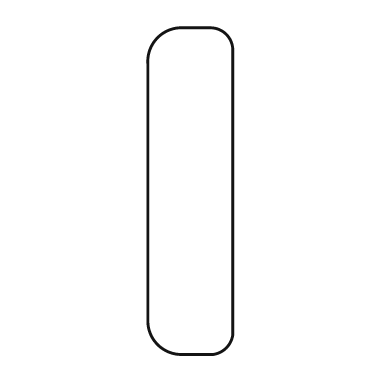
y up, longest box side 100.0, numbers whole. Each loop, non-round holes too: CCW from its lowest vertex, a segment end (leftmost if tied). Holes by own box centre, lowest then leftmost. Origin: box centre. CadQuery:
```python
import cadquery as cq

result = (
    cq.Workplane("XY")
    .moveTo(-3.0, -50.0)
    .lineTo(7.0, -50.0)
    .threePointArc((11.0, -48.0), (13.0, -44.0))
    .lineTo(13.0, 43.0)
    .threePointArc((11.0, 48.0), (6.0, 50.0))
    .lineTo(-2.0, 50.0)
    .threePointArc((-10.0, 47.0), (-13.0, 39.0))
    .lineTo(-13.0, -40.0)
    .threePointArc((-10.0, -47.0), (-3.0, -50.0))
    .close()
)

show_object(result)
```